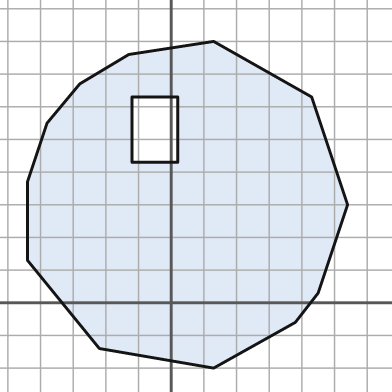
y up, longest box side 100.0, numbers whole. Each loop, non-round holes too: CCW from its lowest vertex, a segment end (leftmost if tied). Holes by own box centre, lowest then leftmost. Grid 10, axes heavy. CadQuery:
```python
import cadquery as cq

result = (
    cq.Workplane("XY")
    .moveTo(13.0, -20.0)
    .lineTo(38.0, -6.0)
    .lineTo(45.0, 3.0)
    .lineTo(54.0, 30.0)
    .lineTo(43.0, 63.0)
    .lineTo(13.0, 80.0)
    .lineTo(-13.0, 76.0)
    .lineTo(-28.0, 67.0)
    .lineTo(-38.0, 55.0)
    .lineTo(-44.0, 37.0)
    .lineTo(-44.0, 13.0)
    .lineTo(-22.0, -14.0)
    .close()
    .moveTo(-12.0, 43.0)
    .lineTo(2.0, 43.0)
    .lineTo(2.0, 63.0)
    .lineTo(-12.0, 63.0)
    .close()
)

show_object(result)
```